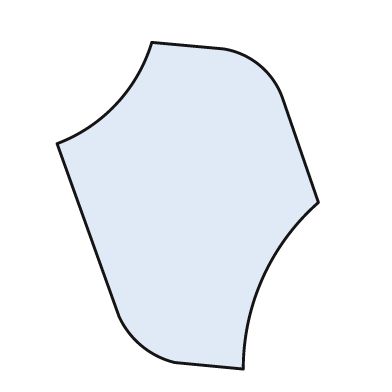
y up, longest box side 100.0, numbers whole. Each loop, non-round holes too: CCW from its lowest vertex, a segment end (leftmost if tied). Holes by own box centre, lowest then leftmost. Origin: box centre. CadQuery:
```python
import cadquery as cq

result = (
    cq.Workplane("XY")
    .moveTo(17.0, -50.0)
    .threePointArc((23.0, -22.0), (40.0, 1.0))
    .lineTo(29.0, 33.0)
    .threePointArc((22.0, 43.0), (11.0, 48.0))
    .lineTo(-11.0, 50.0)
    .threePointArc((-22.0, 31.0), (-40.0, 19.0))
    .lineTo(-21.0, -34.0)
    .threePointArc((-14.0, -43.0), (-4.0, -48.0))
    .close()
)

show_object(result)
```